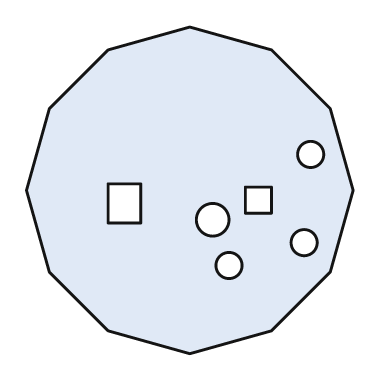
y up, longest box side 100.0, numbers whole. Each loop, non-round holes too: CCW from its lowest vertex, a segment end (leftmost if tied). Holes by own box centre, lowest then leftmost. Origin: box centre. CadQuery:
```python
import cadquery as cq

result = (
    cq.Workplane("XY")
    .moveTo(0.0, -50.0)
    .lineTo(25.0, -43.0)
    .lineTo(43.0, -25.0)
    .lineTo(50.0, 0.0)
    .lineTo(43.0, 25.0)
    .lineTo(25.0, 43.0)
    .lineTo(0.0, 50.0)
    .lineTo(-25.0, 43.0)
    .lineTo(-43.0, 25.0)
    .lineTo(-50.0, 0.0)
    .lineTo(-43.0, -25.0)
    .lineTo(-25.0, -43.0)
    .close()
    .moveTo(12.0, -23.0)
    .circle(4.0)
    .moveTo(35.0, -16.0)
    .circle(4.0)
    .moveTo(7.0, -9.0)
    .circle(5.0)
    .moveTo(-25.0, -10.0)
    .lineTo(-15.0, -10.0)
    .lineTo(-15.0, 2.0)
    .lineTo(-25.0, 2.0)
    .close()
    .moveTo(17.0, -7.0)
    .lineTo(25.0, -7.0)
    .lineTo(25.0, 1.0)
    .lineTo(17.0, 1.0)
    .close()
    .moveTo(37.0, 11.0)
    .circle(4.0)
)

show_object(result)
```